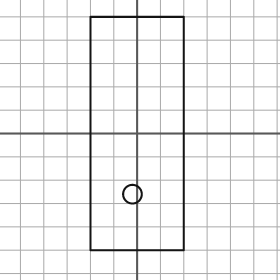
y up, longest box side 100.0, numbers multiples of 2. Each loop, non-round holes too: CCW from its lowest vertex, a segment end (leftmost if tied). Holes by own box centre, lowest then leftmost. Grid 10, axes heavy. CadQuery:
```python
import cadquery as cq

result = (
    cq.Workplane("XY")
    .moveTo(-20.0, -50.0)
    .lineTo(20.0, -50.0)
    .lineTo(20.0, 50.0)
    .lineTo(-20.0, 50.0)
    .close()
    .moveTo(-2.0, -26.0)
    .circle(4.0)
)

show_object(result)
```